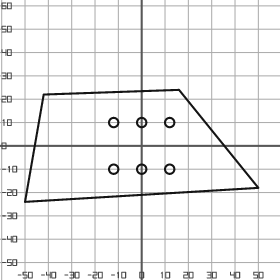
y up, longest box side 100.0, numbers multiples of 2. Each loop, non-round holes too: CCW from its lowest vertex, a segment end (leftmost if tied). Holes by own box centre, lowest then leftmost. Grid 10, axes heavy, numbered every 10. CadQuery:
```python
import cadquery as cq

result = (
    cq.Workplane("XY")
    .moveTo(-50.0, -24.0)
    .lineTo(50.0, -18.0)
    .lineTo(16.0, 24.0)
    .lineTo(-42.0, 22.0)
    .close()
    .moveTo(-12.0, -10.0)
    .circle(2.0)
    .moveTo(0.0, -10.0)
    .circle(2.0)
    .moveTo(12.0, -10.0)
    .circle(2.0)
    .moveTo(-12.0, 10.0)
    .circle(2.0)
    .moveTo(0.0, 10.0)
    .circle(2.0)
    .moveTo(12.0, 10.0)
    .circle(2.0)
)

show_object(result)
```